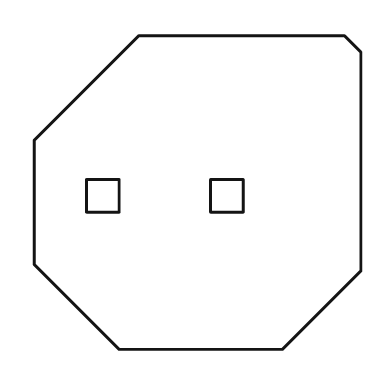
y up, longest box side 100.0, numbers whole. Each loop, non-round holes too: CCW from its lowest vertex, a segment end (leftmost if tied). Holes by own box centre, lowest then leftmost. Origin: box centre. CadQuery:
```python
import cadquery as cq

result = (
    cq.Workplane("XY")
    .moveTo(-24.0, -48.0)
    .lineTo(26.0, -48.0)
    .lineTo(50.0, -24.0)
    .lineTo(50.0, 43.0)
    .lineTo(45.0, 48.0)
    .lineTo(-18.0, 48.0)
    .lineTo(-50.0, 16.0)
    .lineTo(-50.0, -22.0)
    .close()
    .moveTo(-34.0, -6.0)
    .lineTo(-24.0, -6.0)
    .lineTo(-24.0, 4.0)
    .lineTo(-34.0, 4.0)
    .close()
    .moveTo(4.0, -6.0)
    .lineTo(14.0, -6.0)
    .lineTo(14.0, 4.0)
    .lineTo(4.0, 4.0)
    .close()
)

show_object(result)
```